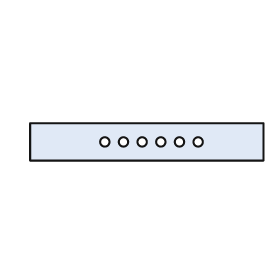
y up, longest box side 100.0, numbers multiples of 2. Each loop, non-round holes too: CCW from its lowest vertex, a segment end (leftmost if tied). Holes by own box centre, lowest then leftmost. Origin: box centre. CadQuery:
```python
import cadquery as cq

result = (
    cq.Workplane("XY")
    .moveTo(-50.0, -8.0)
    .lineTo(50.0, -8.0)
    .lineTo(50.0, 8.0)
    .lineTo(-50.0, 8.0)
    .close()
    .moveTo(-18.0, 0.0)
    .circle(2.0)
    .moveTo(-10.0, 0.0)
    .circle(2.0)
    .moveTo(-2.0, 0.0)
    .circle(2.0)
    .moveTo(6.0, 0.0)
    .circle(2.0)
    .moveTo(14.0, 0.0)
    .circle(2.0)
    .moveTo(22.0, 0.0)
    .circle(2.0)
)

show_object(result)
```